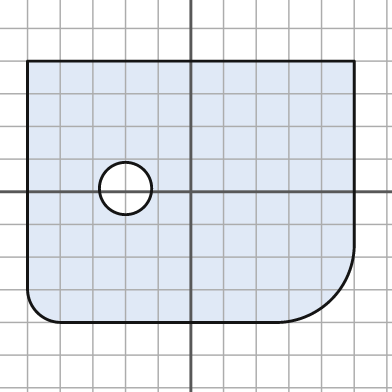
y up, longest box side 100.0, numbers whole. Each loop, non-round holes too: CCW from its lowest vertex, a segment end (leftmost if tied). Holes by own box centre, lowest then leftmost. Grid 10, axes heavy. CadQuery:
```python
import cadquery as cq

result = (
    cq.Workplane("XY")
    .moveTo(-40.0, -40.0)
    .lineTo(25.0, -40.0)
    .threePointArc((43.0, -33.0), (50.0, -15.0))
    .lineTo(50.0, 40.0)
    .lineTo(-50.0, 40.0)
    .lineTo(-50.0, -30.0)
    .threePointArc((-47.0, -37.0), (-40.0, -40.0))
    .close()
    .moveTo(-20.0, 1.0)
    .circle(8.0)
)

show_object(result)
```